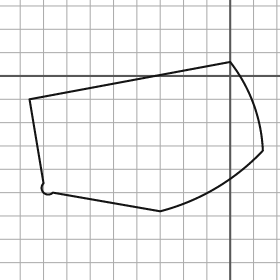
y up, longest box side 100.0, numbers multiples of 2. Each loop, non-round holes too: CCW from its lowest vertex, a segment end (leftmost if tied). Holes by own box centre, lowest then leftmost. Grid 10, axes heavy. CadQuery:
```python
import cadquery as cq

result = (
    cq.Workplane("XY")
    .moveTo(-30.0, -58.0)
    .threePointArc((-6.0, -48.0), (14.0, -32.0))
    .threePointArc((10.0, -12.0), (0.0, 6.0))
    .lineTo(-86.0, -10.0)
    .lineTo(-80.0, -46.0)
    .threePointArc((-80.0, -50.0), (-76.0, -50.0))
    .close()
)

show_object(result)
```